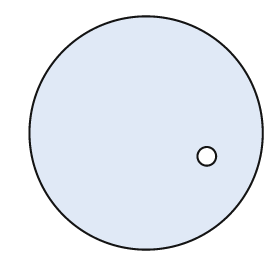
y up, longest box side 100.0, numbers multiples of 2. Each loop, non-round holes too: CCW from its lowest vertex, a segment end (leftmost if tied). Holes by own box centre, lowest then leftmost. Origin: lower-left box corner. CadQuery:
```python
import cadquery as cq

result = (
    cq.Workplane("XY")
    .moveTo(50.0, 50.0)
    .circle(50.0)
    .moveTo(76.0, 40.0)
    .circle(4.0)
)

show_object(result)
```